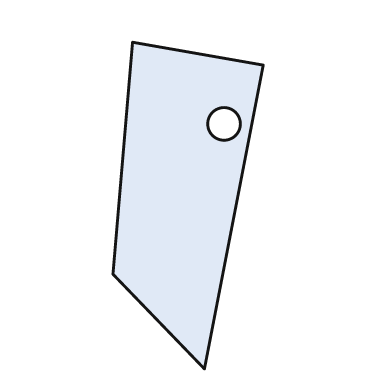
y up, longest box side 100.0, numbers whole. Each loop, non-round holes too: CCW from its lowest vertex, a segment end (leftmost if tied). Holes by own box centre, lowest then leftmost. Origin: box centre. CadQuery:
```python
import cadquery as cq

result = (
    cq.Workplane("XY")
    .moveTo(5.0, -50.0)
    .lineTo(23.0, 43.0)
    .lineTo(-17.0, 50.0)
    .lineTo(-23.0, -21.0)
    .close()
    .moveTo(11.0, 25.0)
    .circle(5.0)
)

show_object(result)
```